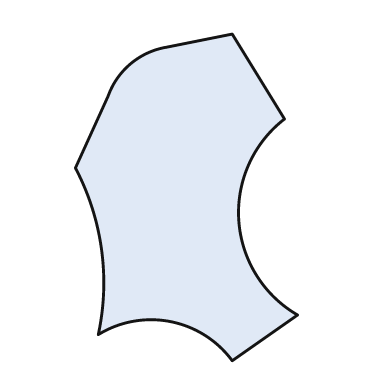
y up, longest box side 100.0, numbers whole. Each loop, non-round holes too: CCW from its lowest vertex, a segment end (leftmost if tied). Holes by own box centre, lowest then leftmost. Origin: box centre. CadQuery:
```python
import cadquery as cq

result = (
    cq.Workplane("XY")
    .moveTo(14.0, -50.0)
    .lineTo(34.0, -36.0)
    .threePointArc((16.0, -7.0), (30.0, 24.0))
    .lineTo(14.0, 50.0)
    .lineTo(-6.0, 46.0)
    .threePointArc((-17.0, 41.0), (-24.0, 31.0))
    .lineTo(-34.0, 9.0)
    .threePointArc((-26.0, -16.0), (-27.0, -42.0))
    .threePointArc((-5.0, -38.0), (14.0, -50.0))
    .close()
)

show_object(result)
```